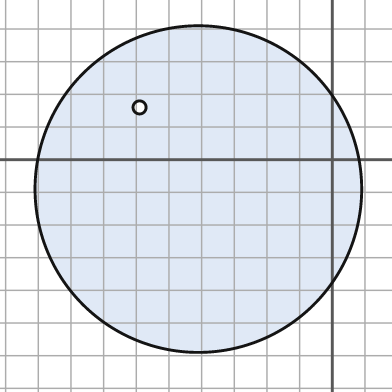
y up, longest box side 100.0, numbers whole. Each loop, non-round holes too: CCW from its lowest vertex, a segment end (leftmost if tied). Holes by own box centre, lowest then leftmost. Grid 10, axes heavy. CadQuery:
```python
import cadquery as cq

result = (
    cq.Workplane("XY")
    .moveTo(-41.0, -9.0)
    .circle(50.0)
    .moveTo(-59.0, 16.0)
    .circle(2.0)
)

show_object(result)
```